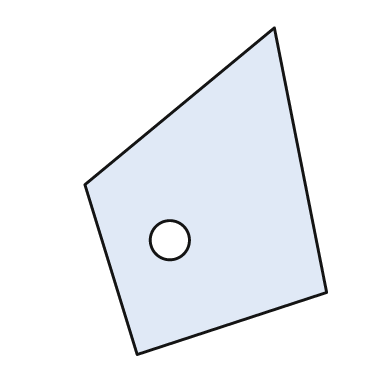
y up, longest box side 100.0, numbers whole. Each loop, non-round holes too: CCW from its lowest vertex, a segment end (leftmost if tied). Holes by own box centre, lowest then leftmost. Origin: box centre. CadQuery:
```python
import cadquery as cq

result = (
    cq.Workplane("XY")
    .moveTo(-21.0, -50.0)
    .lineTo(37.0, -31.0)
    .lineTo(21.0, 50.0)
    .lineTo(-37.0, 2.0)
    .close()
    .moveTo(-11.0, -15.0)
    .circle(6.0)
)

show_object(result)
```